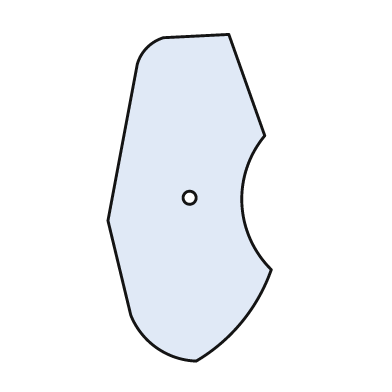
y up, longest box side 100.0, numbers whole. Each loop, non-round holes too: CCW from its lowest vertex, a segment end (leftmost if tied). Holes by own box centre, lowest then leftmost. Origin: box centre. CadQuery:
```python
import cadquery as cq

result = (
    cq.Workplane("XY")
    .moveTo(2.0, -50.0)
    .threePointArc((16.0, -38.0), (25.0, -22.0))
    .threePointArc((16.0, -2.0), (23.0, 19.0))
    .lineTo(12.0, 50.0)
    .lineTo(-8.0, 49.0)
    .threePointArc((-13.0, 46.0), (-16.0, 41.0))
    .lineTo(-25.0, -7.0)
    .lineTo(-18.0, -36.0)
    .threePointArc((-10.0, -46.0), (2.0, -50.0))
    .close()
    .moveTo(0.0, 0.0)
    .circle(2.0)
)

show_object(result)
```